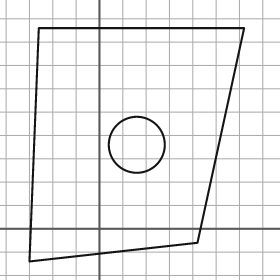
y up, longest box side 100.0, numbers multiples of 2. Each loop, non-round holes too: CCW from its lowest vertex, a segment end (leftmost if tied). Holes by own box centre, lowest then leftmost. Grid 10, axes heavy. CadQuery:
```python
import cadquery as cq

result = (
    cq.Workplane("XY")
    .moveTo(-30.0, -14.0)
    .lineTo(42.0, -6.0)
    .lineTo(62.0, 86.0)
    .lineTo(-26.0, 86.0)
    .close()
    .moveTo(16.0, 36.0)
    .circle(12.0)
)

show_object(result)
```